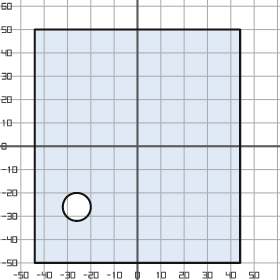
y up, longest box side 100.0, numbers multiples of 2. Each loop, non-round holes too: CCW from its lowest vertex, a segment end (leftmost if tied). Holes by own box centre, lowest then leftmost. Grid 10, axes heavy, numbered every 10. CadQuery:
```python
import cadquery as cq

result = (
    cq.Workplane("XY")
    .moveTo(-44.0, -50.0)
    .lineTo(44.0, -50.0)
    .lineTo(44.0, 50.0)
    .lineTo(-44.0, 50.0)
    .close()
    .moveTo(-26.0, -26.0)
    .circle(6.0)
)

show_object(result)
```